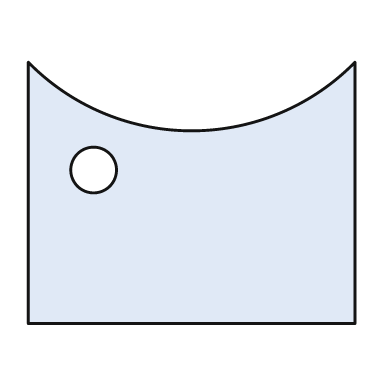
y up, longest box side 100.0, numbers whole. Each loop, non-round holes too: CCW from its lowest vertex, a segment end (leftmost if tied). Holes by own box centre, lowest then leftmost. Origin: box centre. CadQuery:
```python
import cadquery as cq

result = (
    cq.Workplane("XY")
    .moveTo(-50.0, -40.0)
    .lineTo(50.0, -40.0)
    .lineTo(50.0, 40.0)
    .threePointArc((0.0, 19.0), (-50.0, 40.0))
    .close()
    .moveTo(-30.0, 7.0)
    .circle(7.0)
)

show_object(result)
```